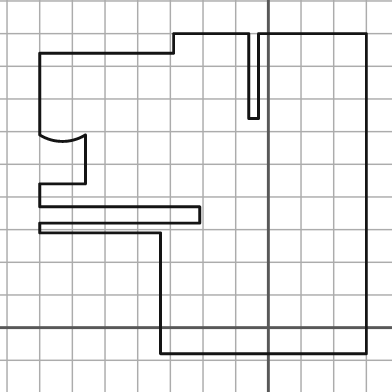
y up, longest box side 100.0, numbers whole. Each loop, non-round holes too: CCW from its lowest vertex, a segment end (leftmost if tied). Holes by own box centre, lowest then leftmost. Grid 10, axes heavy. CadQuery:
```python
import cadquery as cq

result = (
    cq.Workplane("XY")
    .moveTo(-33.0, -8.0)
    .lineTo(30.0, -8.0)
    .lineTo(30.0, 90.0)
    .lineTo(-3.0, 90.0)
    .lineTo(-3.0, 64.0)
    .lineTo(-6.0, 64.0)
    .lineTo(-6.0, 90.0)
    .lineTo(-29.0, 90.0)
    .lineTo(-29.0, 84.0)
    .lineTo(-70.0, 84.0)
    .lineTo(-70.0, 59.0)
    .threePointArc((-63.0, 57.0), (-56.0, 59.0))
    .lineTo(-56.0, 44.0)
    .lineTo(-70.0, 44.0)
    .lineTo(-70.0, 37.0)
    .lineTo(-21.0, 37.0)
    .lineTo(-21.0, 32.0)
    .lineTo(-70.0, 32.0)
    .lineTo(-70.0, 29.0)
    .lineTo(-33.0, 29.0)
    .close()
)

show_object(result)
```